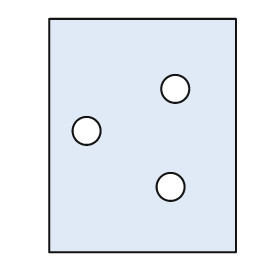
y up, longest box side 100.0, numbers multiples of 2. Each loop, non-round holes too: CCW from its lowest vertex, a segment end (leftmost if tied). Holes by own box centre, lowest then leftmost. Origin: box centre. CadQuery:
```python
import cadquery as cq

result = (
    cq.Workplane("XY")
    .moveTo(-40.0, -50.0)
    .lineTo(40.0, -50.0)
    .lineTo(40.0, 50.0)
    .lineTo(-40.0, 50.0)
    .close()
    .moveTo(12.0, -22.0)
    .circle(6.0)
    .moveTo(-24.0, 2.0)
    .circle(6.0)
    .moveTo(14.0, 20.0)
    .circle(6.0)
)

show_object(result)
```